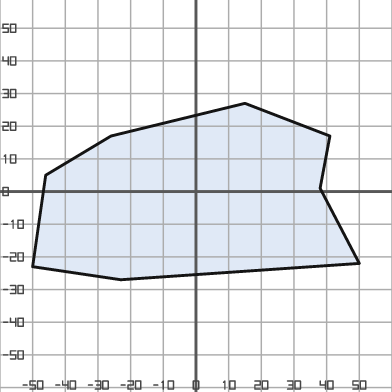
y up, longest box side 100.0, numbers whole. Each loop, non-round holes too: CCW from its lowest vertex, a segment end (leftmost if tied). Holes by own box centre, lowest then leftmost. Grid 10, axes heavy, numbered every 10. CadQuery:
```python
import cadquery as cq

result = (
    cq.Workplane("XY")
    .moveTo(-23.0, -27.0)
    .lineTo(50.0, -22.0)
    .lineTo(38.0, 1.0)
    .lineTo(41.0, 17.0)
    .lineTo(15.0, 27.0)
    .lineTo(-26.0, 17.0)
    .lineTo(-46.0, 5.0)
    .lineTo(-50.0, -23.0)
    .close()
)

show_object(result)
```